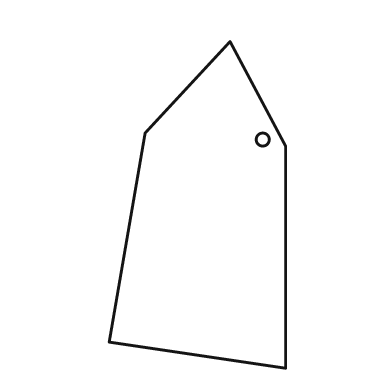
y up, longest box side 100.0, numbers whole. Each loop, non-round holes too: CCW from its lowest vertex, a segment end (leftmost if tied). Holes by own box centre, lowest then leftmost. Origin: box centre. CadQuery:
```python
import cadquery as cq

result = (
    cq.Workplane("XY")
    .moveTo(27.0, -50.0)
    .lineTo(27.0, 18.0)
    .lineTo(10.0, 50.0)
    .lineTo(-16.0, 22.0)
    .lineTo(-27.0, -42.0)
    .close()
    .moveTo(20.0, 20.0)
    .circle(2.0)
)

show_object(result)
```